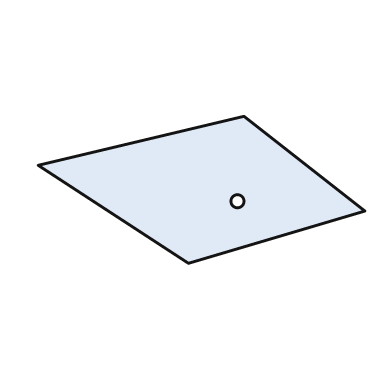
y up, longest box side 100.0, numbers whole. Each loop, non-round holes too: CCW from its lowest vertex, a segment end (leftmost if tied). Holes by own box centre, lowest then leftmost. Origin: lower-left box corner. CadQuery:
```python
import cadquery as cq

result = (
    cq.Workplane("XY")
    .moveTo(46.0, 0.0)
    .lineTo(100.0, 16.0)
    .lineTo(63.0, 45.0)
    .lineTo(0.0, 30.0)
    .close()
    .moveTo(61.0, 19.0)
    .circle(2.0)
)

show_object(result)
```